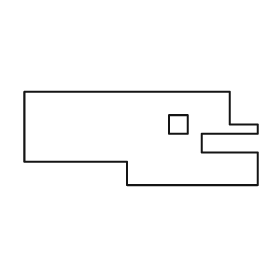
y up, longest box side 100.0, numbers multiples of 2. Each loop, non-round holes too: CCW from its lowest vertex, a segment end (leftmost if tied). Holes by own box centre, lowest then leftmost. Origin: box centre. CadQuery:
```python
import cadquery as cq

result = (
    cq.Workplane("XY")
    .moveTo(-6.0, -20.0)
    .lineTo(50.0, -20.0)
    .lineTo(50.0, -6.0)
    .lineTo(26.0, -6.0)
    .lineTo(26.0, 2.0)
    .lineTo(50.0, 2.0)
    .lineTo(50.0, 6.0)
    .lineTo(38.0, 6.0)
    .lineTo(38.0, 20.0)
    .lineTo(-50.0, 20.0)
    .lineTo(-50.0, -10.0)
    .lineTo(-6.0, -10.0)
    .close()
    .moveTo(12.0, 2.0)
    .lineTo(20.0, 2.0)
    .lineTo(20.0, 10.0)
    .lineTo(12.0, 10.0)
    .close()
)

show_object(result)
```